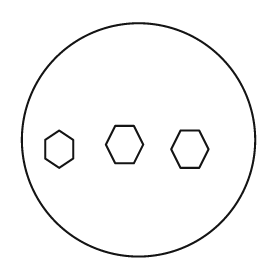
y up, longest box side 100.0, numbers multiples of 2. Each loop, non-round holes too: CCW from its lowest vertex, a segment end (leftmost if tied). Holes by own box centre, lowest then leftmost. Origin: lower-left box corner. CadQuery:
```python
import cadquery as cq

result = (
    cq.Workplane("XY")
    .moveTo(50.0, 50.0)
    .circle(50.0)
    .moveTo(16.0, 38.0)
    .lineTo(22.0, 42.0)
    .lineTo(22.0, 50.0)
    .lineTo(16.0, 54.0)
    .lineTo(10.0, 50.0)
    .lineTo(10.0, 42.0)
    .close()
    .moveTo(68.0, 38.0)
    .lineTo(76.0, 38.0)
    .lineTo(80.0, 46.0)
    .lineTo(76.0, 54.0)
    .lineTo(68.0, 54.0)
    .lineTo(64.0, 46.0)
    .close()
    .moveTo(40.0, 40.0)
    .lineTo(48.0, 40.0)
    .lineTo(52.0, 48.0)
    .lineTo(48.0, 56.0)
    .lineTo(40.0, 56.0)
    .lineTo(36.0, 48.0)
    .close()
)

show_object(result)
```